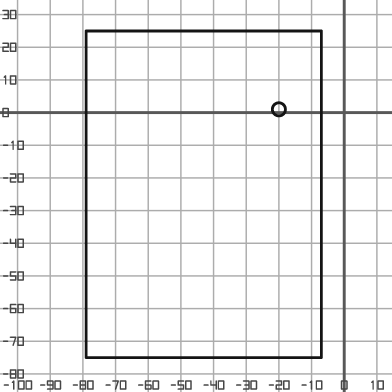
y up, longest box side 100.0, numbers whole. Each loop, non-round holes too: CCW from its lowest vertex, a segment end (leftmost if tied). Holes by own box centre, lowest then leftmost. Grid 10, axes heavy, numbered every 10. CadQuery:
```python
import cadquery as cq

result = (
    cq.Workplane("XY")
    .moveTo(-79.0, -75.0)
    .lineTo(-7.0, -75.0)
    .lineTo(-7.0, 25.0)
    .lineTo(-79.0, 25.0)
    .close()
    .moveTo(-20.0, 1.0)
    .circle(2.0)
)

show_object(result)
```